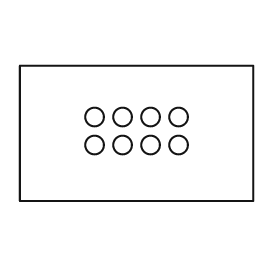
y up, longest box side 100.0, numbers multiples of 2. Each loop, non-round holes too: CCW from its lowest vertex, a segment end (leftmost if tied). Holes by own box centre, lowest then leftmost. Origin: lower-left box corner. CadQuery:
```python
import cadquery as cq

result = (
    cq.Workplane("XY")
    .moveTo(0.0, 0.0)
    .lineTo(100.0, 0.0)
    .lineTo(100.0, 58.0)
    .lineTo(0.0, 58.0)
    .close()
    .moveTo(32.0, 24.0)
    .circle(4.0)
    .moveTo(44.0, 24.0)
    .circle(4.0)
    .moveTo(56.0, 24.0)
    .circle(4.0)
    .moveTo(68.0, 24.0)
    .circle(4.0)
    .moveTo(32.0, 36.0)
    .circle(4.0)
    .moveTo(44.0, 36.0)
    .circle(4.0)
    .moveTo(56.0, 36.0)
    .circle(4.0)
    .moveTo(68.0, 36.0)
    .circle(4.0)
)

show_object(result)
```